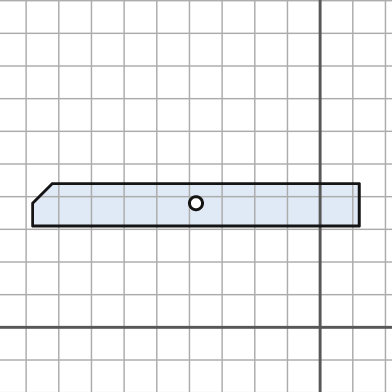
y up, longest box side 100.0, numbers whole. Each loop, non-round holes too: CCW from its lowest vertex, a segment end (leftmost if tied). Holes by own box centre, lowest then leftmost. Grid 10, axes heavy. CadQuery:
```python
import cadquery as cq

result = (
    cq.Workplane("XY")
    .moveTo(-88.0, 31.0)
    .lineTo(12.0, 31.0)
    .lineTo(12.0, 44.0)
    .lineTo(-82.0, 44.0)
    .lineTo(-88.0, 38.0)
    .close()
    .moveTo(-38.0, 38.0)
    .circle(2.0)
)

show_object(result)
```